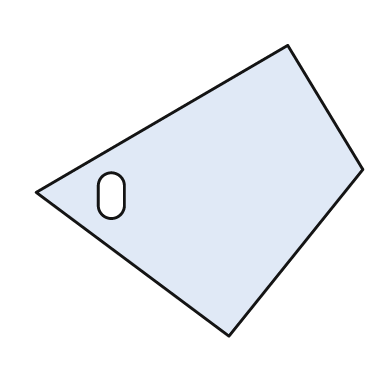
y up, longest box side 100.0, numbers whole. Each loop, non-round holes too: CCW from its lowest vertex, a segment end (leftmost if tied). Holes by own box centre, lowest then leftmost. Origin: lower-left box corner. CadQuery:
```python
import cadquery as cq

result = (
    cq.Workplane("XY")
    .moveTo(59.0, 0.0)
    .lineTo(100.0, 51.0)
    .lineTo(77.0, 89.0)
    .lineTo(0.0, 44.0)
    .close()
    .moveTo(19.0, 40.0)
    .threePointArc((23.0, 36.0), (27.0, 40.0))
    .lineTo(27.0, 46.0)
    .threePointArc((23.0, 50.0), (19.0, 46.0))
    .close()
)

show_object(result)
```